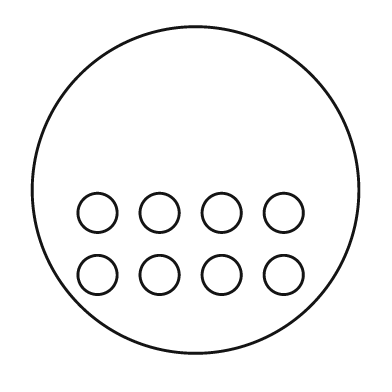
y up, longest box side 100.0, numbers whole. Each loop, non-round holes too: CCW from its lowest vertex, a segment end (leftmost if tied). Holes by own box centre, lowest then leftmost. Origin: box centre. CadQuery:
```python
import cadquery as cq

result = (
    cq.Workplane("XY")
    .moveTo(0.0, 0.0)
    .circle(50.0)
    .moveTo(-30.0, -26.0)
    .circle(6.0)
    .moveTo(-11.0, -26.0)
    .circle(6.0)
    .moveTo(8.0, -26.0)
    .circle(6.0)
    .moveTo(27.0, -26.0)
    .circle(6.0)
    .moveTo(-30.0, -7.0)
    .circle(6.0)
    .moveTo(-11.0, -7.0)
    .circle(6.0)
    .moveTo(8.0, -7.0)
    .circle(6.0)
    .moveTo(27.0, -7.0)
    .circle(6.0)
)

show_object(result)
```